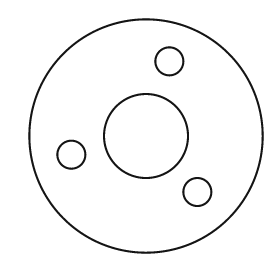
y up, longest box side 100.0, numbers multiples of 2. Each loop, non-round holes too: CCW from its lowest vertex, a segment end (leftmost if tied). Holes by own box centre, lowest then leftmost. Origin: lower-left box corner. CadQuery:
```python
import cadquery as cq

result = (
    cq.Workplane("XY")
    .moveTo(50.0, 50.0)
    .circle(50.0)
    .moveTo(72.0, 26.0)
    .circle(6.0)
    .moveTo(18.0, 42.0)
    .circle(6.0)
    .moveTo(50.0, 50.0)
    .circle(18.0)
    .moveTo(60.0, 82.0)
    .circle(6.0)
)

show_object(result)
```